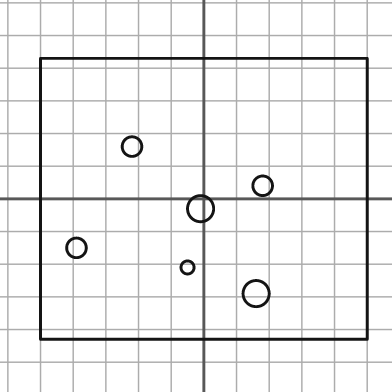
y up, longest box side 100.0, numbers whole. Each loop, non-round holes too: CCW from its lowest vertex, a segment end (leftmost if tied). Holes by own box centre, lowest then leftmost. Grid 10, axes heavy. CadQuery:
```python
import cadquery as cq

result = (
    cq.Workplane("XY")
    .moveTo(-50.0, -43.0)
    .lineTo(50.0, -43.0)
    .lineTo(50.0, 43.0)
    .lineTo(-50.0, 43.0)
    .close()
    .moveTo(16.0, -29.0)
    .circle(4.0)
    .moveTo(-5.0, -21.0)
    .circle(2.0)
    .moveTo(-39.0, -15.0)
    .circle(3.0)
    .moveTo(-1.0, -3.0)
    .circle(4.0)
    .moveTo(18.0, 4.0)
    .circle(3.0)
    .moveTo(-22.0, 16.0)
    .circle(3.0)
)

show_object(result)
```